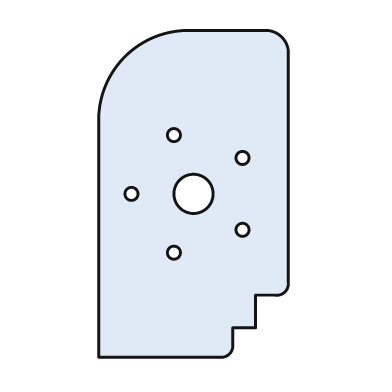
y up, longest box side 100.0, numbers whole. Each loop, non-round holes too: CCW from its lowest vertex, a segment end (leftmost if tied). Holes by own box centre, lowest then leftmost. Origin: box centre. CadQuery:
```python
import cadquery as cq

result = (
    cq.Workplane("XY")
    .moveTo(-29.0, -50.0)
    .lineTo(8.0, -50.0)
    .threePointArc((11.0, -49.0), (12.0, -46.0))
    .lineTo(12.0, -41.0)
    .lineTo(19.0, -41.0)
    .lineTo(19.0, -31.0)
    .lineTo(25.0, -31.0)
    .threePointArc((28.0, -30.0), (29.0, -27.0))
    .lineTo(29.0, 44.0)
    .threePointArc((27.0, 48.0), (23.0, 50.0))
    .lineTo(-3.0, 50.0)
    .threePointArc((-21.0, 42.0), (-29.0, 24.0))
    .close()
    .moveTo(-6.0, -18.0)
    .circle(2.0)
    .moveTo(15.0, -11.0)
    .circle(2.0)
    .moveTo(-19.0, 0.0)
    .circle(2.0)
    .moveTo(0.0, 0.0)
    .circle(6.0)
    .moveTo(15.0, 11.0)
    .circle(2.0)
    .moveTo(-6.0, 18.0)
    .circle(2.0)
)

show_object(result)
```